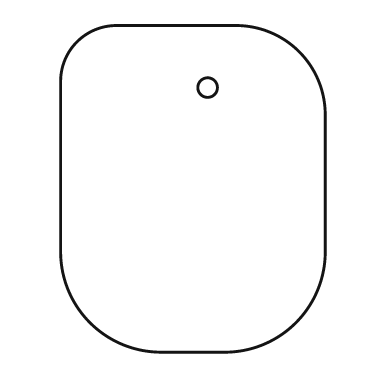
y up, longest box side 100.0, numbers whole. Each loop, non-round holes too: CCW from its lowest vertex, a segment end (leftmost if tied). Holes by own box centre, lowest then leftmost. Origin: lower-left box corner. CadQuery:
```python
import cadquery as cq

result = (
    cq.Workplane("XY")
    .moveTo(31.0, 0.0)
    .lineTo(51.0, 0.0)
    .threePointArc((72.0, 9.0), (81.0, 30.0))
    .lineTo(81.0, 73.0)
    .threePointArc((73.0, 92.0), (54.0, 100.0))
    .lineTo(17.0, 100.0)
    .threePointArc((5.0, 95.0), (0.0, 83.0))
    .lineTo(0.0, 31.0)
    .threePointArc((9.0, 9.0), (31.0, 0.0))
    .close()
    .moveTo(45.0, 81.0)
    .circle(3.0)
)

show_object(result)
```